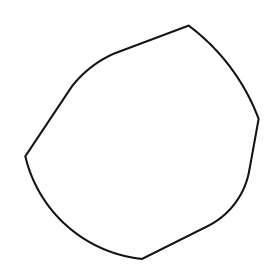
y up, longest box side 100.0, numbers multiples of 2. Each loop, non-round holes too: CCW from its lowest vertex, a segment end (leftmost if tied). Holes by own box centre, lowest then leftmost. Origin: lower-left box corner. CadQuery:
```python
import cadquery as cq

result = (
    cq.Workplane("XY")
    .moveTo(50.0, 0.0)
    .lineTo(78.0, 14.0)
    .threePointArc((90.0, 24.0), (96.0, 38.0))
    .lineTo(100.0, 60.0)
    .threePointArc((88.0, 82.0), (70.0, 100.0))
    .lineTo(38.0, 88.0)
    .threePointArc((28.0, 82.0), (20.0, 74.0))
    .lineTo(0.0, 44.0)
    .threePointArc((18.0, 14.0), (50.0, 0.0))
    .close()
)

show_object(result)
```